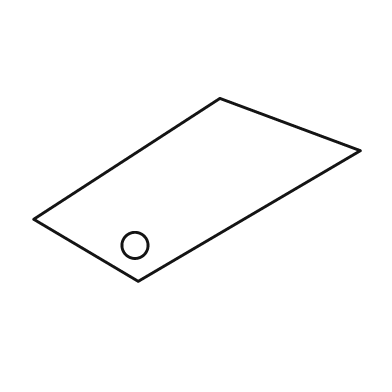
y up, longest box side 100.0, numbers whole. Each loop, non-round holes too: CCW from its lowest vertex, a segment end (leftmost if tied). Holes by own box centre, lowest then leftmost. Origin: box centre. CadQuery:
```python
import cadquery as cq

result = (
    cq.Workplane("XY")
    .moveTo(-18.0, -28.0)
    .lineTo(50.0, 12.0)
    .lineTo(7.0, 28.0)
    .lineTo(-50.0, -9.0)
    .close()
    .moveTo(-19.0, -17.0)
    .circle(4.0)
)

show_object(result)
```